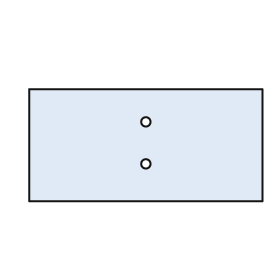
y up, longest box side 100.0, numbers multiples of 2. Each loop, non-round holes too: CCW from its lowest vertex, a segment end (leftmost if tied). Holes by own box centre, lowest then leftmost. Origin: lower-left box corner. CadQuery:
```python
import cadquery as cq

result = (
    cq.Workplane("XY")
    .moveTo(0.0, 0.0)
    .lineTo(100.0, 0.0)
    .lineTo(100.0, 48.0)
    .lineTo(0.0, 48.0)
    .close()
    .moveTo(50.0, 16.0)
    .circle(2.0)
    .moveTo(50.0, 34.0)
    .circle(2.0)
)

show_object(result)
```